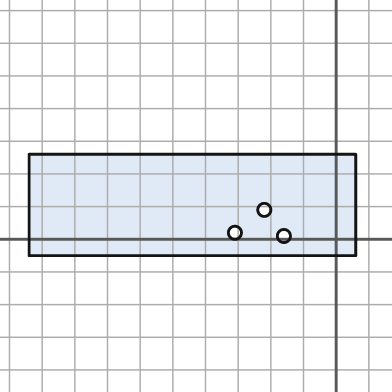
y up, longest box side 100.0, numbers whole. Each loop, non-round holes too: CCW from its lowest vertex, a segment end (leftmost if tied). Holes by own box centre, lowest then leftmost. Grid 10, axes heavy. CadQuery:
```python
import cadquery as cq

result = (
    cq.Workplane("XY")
    .moveTo(-94.0, -5.0)
    .lineTo(6.0, -5.0)
    .lineTo(6.0, 26.0)
    .lineTo(-94.0, 26.0)
    .close()
    .moveTo(-16.0, 1.0)
    .circle(2.0)
    .moveTo(-31.0, 2.0)
    .circle(2.0)
    .moveTo(-22.0, 9.0)
    .circle(2.0)
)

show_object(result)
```